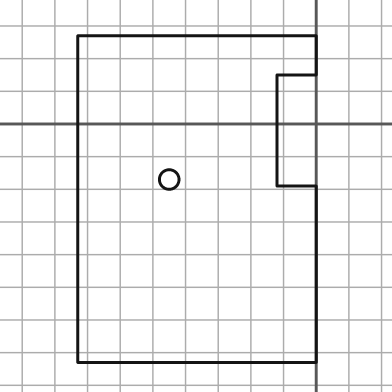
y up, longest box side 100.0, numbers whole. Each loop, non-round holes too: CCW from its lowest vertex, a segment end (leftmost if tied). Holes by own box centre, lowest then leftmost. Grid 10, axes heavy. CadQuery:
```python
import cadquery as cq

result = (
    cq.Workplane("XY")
    .moveTo(-73.0, -73.0)
    .lineTo(0.0, -73.0)
    .lineTo(0.0, -19.0)
    .lineTo(-12.0, -19.0)
    .lineTo(-12.0, 15.0)
    .lineTo(0.0, 15.0)
    .lineTo(0.0, 27.0)
    .lineTo(-73.0, 27.0)
    .close()
    .moveTo(-45.0, -17.0)
    .circle(3.0)
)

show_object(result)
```